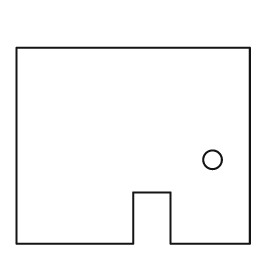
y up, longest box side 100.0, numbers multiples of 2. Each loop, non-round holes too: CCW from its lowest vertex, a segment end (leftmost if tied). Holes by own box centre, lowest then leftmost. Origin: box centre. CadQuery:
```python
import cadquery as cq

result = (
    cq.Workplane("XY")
    .moveTo(-50.0, -42.0)
    .lineTo(0.0, -42.0)
    .lineTo(0.0, -20.0)
    .lineTo(16.0, -20.0)
    .lineTo(16.0, -42.0)
    .lineTo(50.0, -42.0)
    .lineTo(50.0, 42.0)
    .lineTo(-50.0, 42.0)
    .close()
    .moveTo(34.0, -6.0)
    .circle(4.0)
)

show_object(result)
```